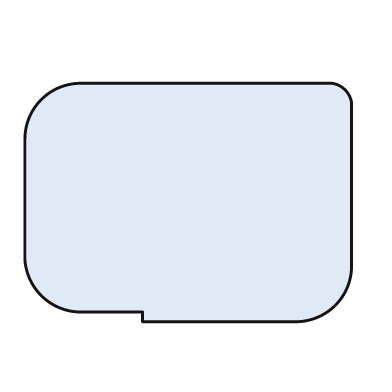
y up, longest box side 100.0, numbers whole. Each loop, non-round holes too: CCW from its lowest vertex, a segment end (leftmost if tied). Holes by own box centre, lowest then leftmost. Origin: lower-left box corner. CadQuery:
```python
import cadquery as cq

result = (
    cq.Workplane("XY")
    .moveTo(36.0, 0.0)
    .lineTo(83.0, 0.0)
    .threePointArc((95.0, 5.0), (100.0, 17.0))
    .lineTo(100.0, 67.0)
    .threePointArc((98.0, 71.0), (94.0, 73.0))
    .lineTo(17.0, 73.0)
    .threePointArc((5.0, 68.0), (0.0, 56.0))
    .lineTo(0.0, 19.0)
    .threePointArc((5.0, 8.0), (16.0, 3.0))
    .lineTo(36.0, 3.0)
    .close()
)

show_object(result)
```